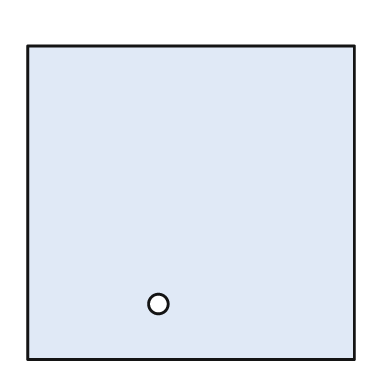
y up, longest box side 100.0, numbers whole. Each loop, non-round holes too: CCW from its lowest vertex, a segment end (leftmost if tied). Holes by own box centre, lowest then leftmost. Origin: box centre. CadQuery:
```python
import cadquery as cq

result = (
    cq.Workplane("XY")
    .moveTo(-50.0, -48.0)
    .lineTo(50.0, -48.0)
    .lineTo(50.0, 48.0)
    .lineTo(-50.0, 48.0)
    .close()
    .moveTo(-10.0, -31.0)
    .circle(3.0)
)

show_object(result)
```